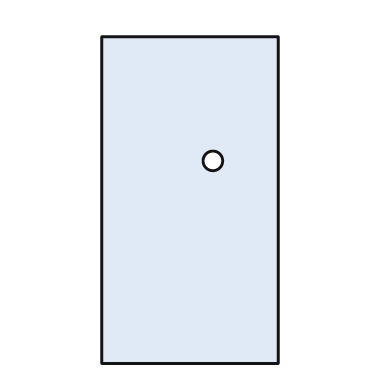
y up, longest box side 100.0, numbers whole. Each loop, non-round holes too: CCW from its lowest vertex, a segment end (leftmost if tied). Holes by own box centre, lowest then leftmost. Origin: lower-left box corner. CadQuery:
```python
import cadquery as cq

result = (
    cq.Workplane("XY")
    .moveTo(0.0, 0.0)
    .lineTo(54.0, 0.0)
    .lineTo(54.0, 100.0)
    .lineTo(0.0, 100.0)
    .close()
    .moveTo(34.0, 62.0)
    .circle(3.0)
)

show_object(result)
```